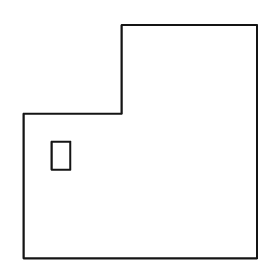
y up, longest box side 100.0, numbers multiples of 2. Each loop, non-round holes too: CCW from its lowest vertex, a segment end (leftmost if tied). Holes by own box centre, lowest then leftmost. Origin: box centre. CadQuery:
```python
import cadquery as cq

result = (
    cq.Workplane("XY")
    .moveTo(-50.0, -50.0)
    .lineTo(50.0, -50.0)
    .lineTo(50.0, 50.0)
    .lineTo(-8.0, 50.0)
    .lineTo(-8.0, 12.0)
    .lineTo(-50.0, 12.0)
    .close()
    .moveTo(-38.0, -12.0)
    .lineTo(-30.0, -12.0)
    .lineTo(-30.0, 0.0)
    .lineTo(-38.0, 0.0)
    .close()
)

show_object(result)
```